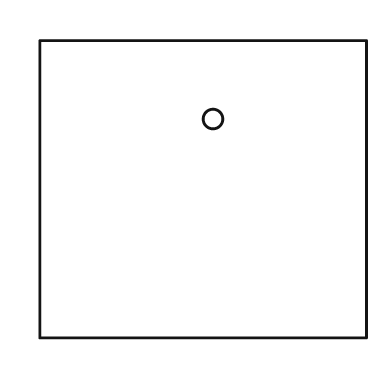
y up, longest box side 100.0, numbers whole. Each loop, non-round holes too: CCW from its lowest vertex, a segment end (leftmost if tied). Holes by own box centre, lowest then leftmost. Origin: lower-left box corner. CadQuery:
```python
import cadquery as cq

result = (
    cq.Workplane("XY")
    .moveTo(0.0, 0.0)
    .lineTo(100.0, 0.0)
    .lineTo(100.0, 91.0)
    .lineTo(0.0, 91.0)
    .close()
    .moveTo(53.0, 67.0)
    .circle(3.0)
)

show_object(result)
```